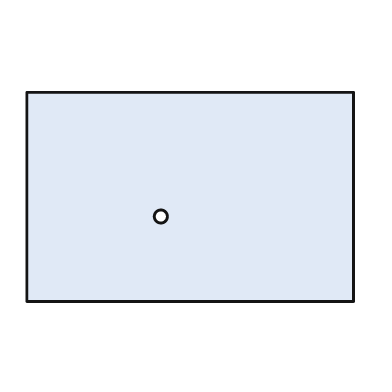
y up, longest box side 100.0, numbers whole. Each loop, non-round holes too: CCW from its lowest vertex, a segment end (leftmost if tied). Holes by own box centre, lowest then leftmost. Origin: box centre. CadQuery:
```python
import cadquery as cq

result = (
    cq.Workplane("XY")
    .moveTo(-50.0, -32.0)
    .lineTo(50.0, -32.0)
    .lineTo(50.0, 32.0)
    .lineTo(-50.0, 32.0)
    .close()
    .moveTo(-9.0, -6.0)
    .circle(2.0)
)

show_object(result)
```